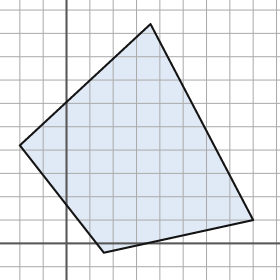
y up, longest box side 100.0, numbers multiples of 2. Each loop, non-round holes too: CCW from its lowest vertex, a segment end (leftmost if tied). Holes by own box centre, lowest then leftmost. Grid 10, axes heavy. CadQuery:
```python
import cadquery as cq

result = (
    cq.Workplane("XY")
    .moveTo(16.0, -4.0)
    .lineTo(80.0, 10.0)
    .lineTo(36.0, 94.0)
    .lineTo(-20.0, 42.0)
    .close()
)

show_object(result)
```